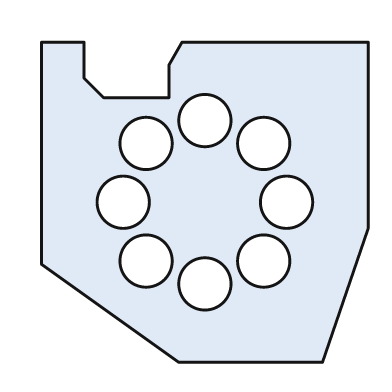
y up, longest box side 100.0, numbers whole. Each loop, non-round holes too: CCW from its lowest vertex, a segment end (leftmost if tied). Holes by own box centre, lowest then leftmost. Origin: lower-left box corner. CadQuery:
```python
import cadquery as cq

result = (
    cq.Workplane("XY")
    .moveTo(42.0, 0.0)
    .lineTo(86.0, 0.0)
    .lineTo(100.0, 41.0)
    .lineTo(100.0, 98.0)
    .lineTo(43.0, 98.0)
    .lineTo(39.0, 91.0)
    .lineTo(39.0, 81.0)
    .lineTo(19.0, 81.0)
    .lineTo(13.0, 87.0)
    .lineTo(13.0, 98.0)
    .lineTo(0.0, 98.0)
    .lineTo(0.0, 30.0)
    .close()
    .moveTo(50.0, 24.0)
    .circle(8.0)
    .moveTo(32.0, 31.0)
    .circle(8.0)
    .moveTo(68.0, 31.0)
    .circle(8.0)
    .moveTo(25.0, 49.0)
    .circle(8.0)
    .moveTo(75.0, 49.0)
    .circle(8.0)
    .moveTo(32.0, 67.0)
    .circle(8.0)
    .moveTo(68.0, 67.0)
    .circle(8.0)
    .moveTo(50.0, 74.0)
    .circle(8.0)
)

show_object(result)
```